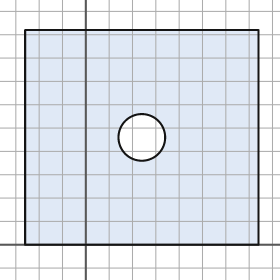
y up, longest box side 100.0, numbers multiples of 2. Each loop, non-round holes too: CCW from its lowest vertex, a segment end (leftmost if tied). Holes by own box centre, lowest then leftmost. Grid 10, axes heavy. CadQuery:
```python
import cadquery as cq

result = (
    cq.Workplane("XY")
    .moveTo(-26.0, 0.0)
    .lineTo(74.0, 0.0)
    .lineTo(74.0, 92.0)
    .lineTo(-26.0, 92.0)
    .close()
    .moveTo(24.0, 46.0)
    .circle(10.0)
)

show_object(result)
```